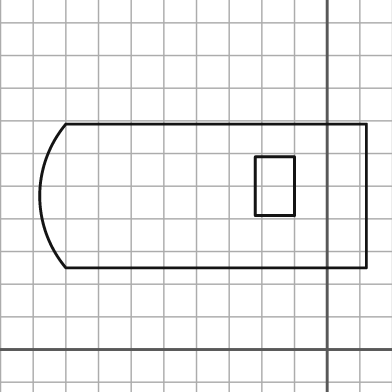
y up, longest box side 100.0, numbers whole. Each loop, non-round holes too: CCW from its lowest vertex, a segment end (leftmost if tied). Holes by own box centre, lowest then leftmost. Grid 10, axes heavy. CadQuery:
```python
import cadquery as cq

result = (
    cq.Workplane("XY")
    .moveTo(-80.0, 25.0)
    .lineTo(12.0, 25.0)
    .lineTo(12.0, 69.0)
    .lineTo(-80.0, 69.0)
    .threePointArc((-88.0, 47.0), (-80.0, 25.0))
    .close()
    .moveTo(-22.0, 41.0)
    .lineTo(-10.0, 41.0)
    .lineTo(-10.0, 59.0)
    .lineTo(-22.0, 59.0)
    .close()
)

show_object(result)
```